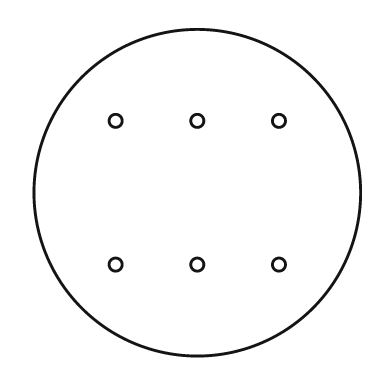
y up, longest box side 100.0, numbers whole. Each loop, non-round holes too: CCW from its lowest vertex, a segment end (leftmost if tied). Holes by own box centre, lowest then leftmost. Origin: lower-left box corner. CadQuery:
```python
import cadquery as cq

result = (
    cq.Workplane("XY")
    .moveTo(50.0, 50.0)
    .circle(50.0)
    .moveTo(25.0, 28.0)
    .circle(2.0)
    .moveTo(50.0, 28.0)
    .circle(2.0)
    .moveTo(75.0, 28.0)
    .circle(2.0)
    .moveTo(25.0, 72.0)
    .circle(2.0)
    .moveTo(50.0, 72.0)
    .circle(2.0)
    .moveTo(75.0, 72.0)
    .circle(2.0)
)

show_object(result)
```